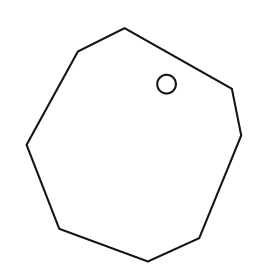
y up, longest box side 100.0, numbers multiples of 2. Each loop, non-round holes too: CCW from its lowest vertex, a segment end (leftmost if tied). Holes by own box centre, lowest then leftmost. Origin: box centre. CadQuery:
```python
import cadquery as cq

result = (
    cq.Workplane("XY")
    .moveTo(6.0, -50.0)
    .lineTo(28.0, -40.0)
    .lineTo(46.0, 4.0)
    .lineTo(42.0, 24.0)
    .lineTo(-4.0, 50.0)
    .lineTo(-24.0, 40.0)
    .lineTo(-46.0, 0.0)
    .lineTo(-32.0, -36.0)
    .close()
    .moveTo(14.0, 26.0)
    .circle(4.0)
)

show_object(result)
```